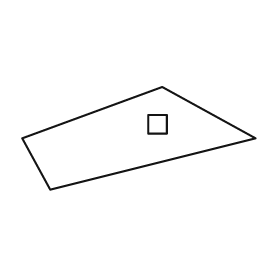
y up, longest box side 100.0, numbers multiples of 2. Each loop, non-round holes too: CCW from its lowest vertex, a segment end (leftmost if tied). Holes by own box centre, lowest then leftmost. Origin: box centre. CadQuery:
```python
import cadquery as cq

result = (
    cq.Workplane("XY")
    .moveTo(-38.0, -22.0)
    .lineTo(50.0, 0.0)
    .lineTo(10.0, 22.0)
    .lineTo(-50.0, 0.0)
    .close()
    .moveTo(4.0, 2.0)
    .lineTo(12.0, 2.0)
    .lineTo(12.0, 10.0)
    .lineTo(4.0, 10.0)
    .close()
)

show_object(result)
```